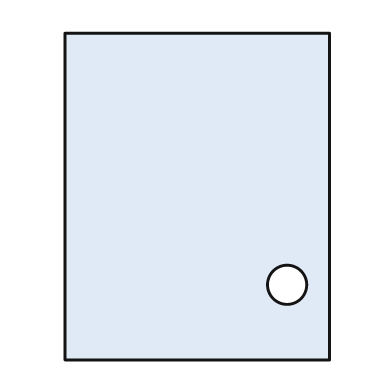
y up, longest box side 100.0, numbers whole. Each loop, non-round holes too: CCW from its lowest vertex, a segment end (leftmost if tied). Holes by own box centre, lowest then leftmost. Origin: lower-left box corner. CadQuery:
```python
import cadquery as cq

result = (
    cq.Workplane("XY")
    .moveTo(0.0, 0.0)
    .lineTo(81.0, 0.0)
    .lineTo(81.0, 100.0)
    .lineTo(0.0, 100.0)
    .close()
    .moveTo(68.0, 23.0)
    .circle(6.0)
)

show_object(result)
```